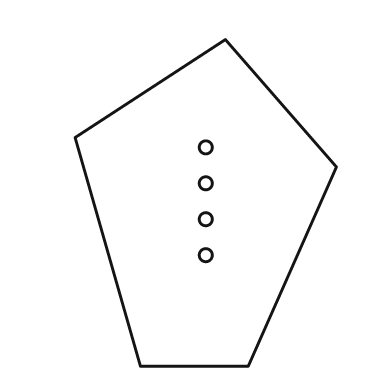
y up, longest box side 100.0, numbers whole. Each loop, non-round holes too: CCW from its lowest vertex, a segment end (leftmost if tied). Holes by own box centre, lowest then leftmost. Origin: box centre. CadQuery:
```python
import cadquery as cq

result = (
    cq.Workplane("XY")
    .moveTo(-20.0, -50.0)
    .lineTo(13.0, -50.0)
    .lineTo(40.0, 11.0)
    .lineTo(6.0, 50.0)
    .lineTo(-40.0, 20.0)
    .close()
    .moveTo(0.0, -16.0)
    .circle(2.0)
    .moveTo(0.0, -5.0)
    .circle(2.0)
    .moveTo(0.0, 6.0)
    .circle(2.0)
    .moveTo(0.0, 17.0)
    .circle(2.0)
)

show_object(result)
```